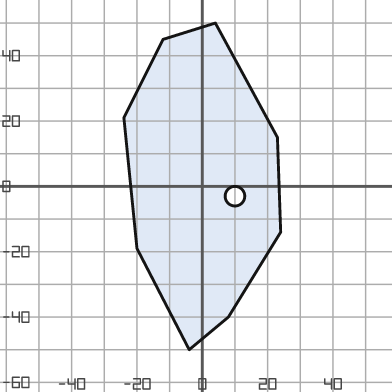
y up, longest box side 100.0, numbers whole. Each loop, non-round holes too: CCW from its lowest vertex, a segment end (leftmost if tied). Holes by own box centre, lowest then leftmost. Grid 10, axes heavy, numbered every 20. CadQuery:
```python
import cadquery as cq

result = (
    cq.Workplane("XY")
    .moveTo(-4.0, -50.0)
    .lineTo(8.0, -40.0)
    .lineTo(24.0, -14.0)
    .lineTo(23.0, 15.0)
    .lineTo(4.0, 50.0)
    .lineTo(-12.0, 45.0)
    .lineTo(-24.0, 21.0)
    .lineTo(-20.0, -19.0)
    .close()
    .moveTo(10.0, -3.0)
    .circle(3.0)
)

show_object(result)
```